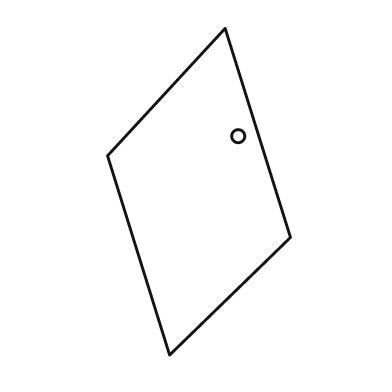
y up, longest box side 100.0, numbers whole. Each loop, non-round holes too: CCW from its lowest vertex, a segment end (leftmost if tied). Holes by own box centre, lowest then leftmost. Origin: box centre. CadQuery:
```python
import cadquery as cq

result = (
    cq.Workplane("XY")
    .moveTo(-9.0, -50.0)
    .lineTo(28.0, -14.0)
    .lineTo(8.0, 50.0)
    .lineTo(-28.0, 11.0)
    .close()
    .moveTo(12.0, 17.0)
    .circle(2.0)
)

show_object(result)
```